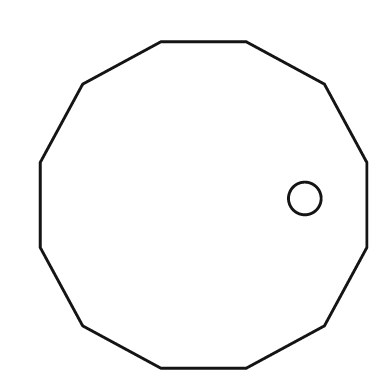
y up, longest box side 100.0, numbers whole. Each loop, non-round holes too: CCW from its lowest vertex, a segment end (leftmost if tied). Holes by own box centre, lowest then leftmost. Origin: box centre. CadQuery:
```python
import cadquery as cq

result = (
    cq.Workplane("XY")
    .moveTo(-13.0, -50.0)
    .lineTo(13.0, -50.0)
    .lineTo(37.0, -37.0)
    .lineTo(50.0, -13.0)
    .lineTo(50.0, 13.0)
    .lineTo(37.0, 37.0)
    .lineTo(13.0, 50.0)
    .lineTo(-13.0, 50.0)
    .lineTo(-37.0, 37.0)
    .lineTo(-50.0, 13.0)
    .lineTo(-50.0, -13.0)
    .lineTo(-37.0, -37.0)
    .close()
    .moveTo(31.0, 2.0)
    .circle(5.0)
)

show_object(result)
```